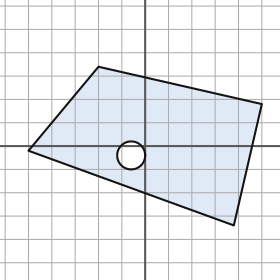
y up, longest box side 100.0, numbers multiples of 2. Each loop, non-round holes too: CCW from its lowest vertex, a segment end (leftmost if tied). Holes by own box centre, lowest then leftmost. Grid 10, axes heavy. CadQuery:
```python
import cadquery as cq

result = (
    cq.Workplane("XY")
    .moveTo(38.0, -34.0)
    .lineTo(50.0, 18.0)
    .lineTo(-20.0, 34.0)
    .lineTo(-50.0, -2.0)
    .close()
    .moveTo(-6.0, -4.0)
    .circle(6.0)
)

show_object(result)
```